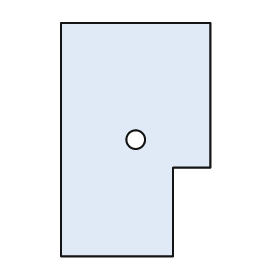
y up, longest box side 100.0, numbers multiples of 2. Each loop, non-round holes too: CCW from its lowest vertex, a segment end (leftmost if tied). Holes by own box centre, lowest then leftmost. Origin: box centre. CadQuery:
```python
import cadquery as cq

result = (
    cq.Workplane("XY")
    .moveTo(-32.0, -50.0)
    .lineTo(16.0, -50.0)
    .lineTo(16.0, -12.0)
    .lineTo(32.0, -12.0)
    .lineTo(32.0, 50.0)
    .lineTo(-32.0, 50.0)
    .close()
    .moveTo(0.0, 0.0)
    .circle(4.0)
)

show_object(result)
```